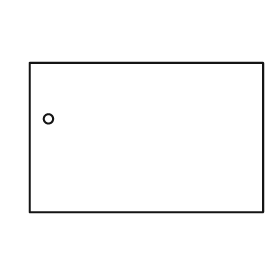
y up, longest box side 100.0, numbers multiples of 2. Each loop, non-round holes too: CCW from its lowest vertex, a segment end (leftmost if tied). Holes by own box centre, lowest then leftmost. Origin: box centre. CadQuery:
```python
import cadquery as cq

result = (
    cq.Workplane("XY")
    .moveTo(-50.0, -32.0)
    .lineTo(50.0, -32.0)
    .lineTo(50.0, 32.0)
    .lineTo(-50.0, 32.0)
    .close()
    .moveTo(-42.0, 8.0)
    .circle(2.0)
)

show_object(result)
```